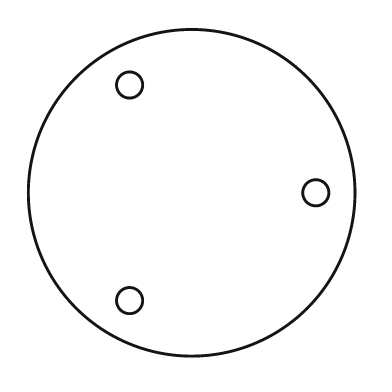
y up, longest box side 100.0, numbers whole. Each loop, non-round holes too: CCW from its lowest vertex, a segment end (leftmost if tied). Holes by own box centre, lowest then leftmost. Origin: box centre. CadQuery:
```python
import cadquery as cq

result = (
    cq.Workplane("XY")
    .moveTo(0.0, 0.0)
    .circle(50.0)
    .moveTo(-19.0, -33.0)
    .circle(4.0)
    .moveTo(38.0, 0.0)
    .circle(4.0)
    .moveTo(-19.0, 33.0)
    .circle(4.0)
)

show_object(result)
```